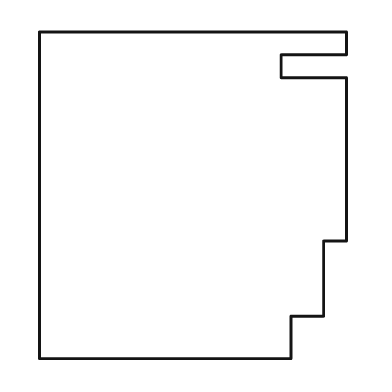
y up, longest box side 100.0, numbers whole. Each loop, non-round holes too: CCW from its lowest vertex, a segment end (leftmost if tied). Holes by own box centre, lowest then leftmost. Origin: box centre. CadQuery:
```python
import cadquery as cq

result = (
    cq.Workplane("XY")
    .moveTo(-47.0, -50.0)
    .lineTo(30.0, -50.0)
    .lineTo(30.0, -37.0)
    .lineTo(40.0, -37.0)
    .lineTo(40.0, -14.0)
    .lineTo(47.0, -14.0)
    .lineTo(47.0, 36.0)
    .lineTo(27.0, 36.0)
    .lineTo(27.0, 43.0)
    .lineTo(47.0, 43.0)
    .lineTo(47.0, 50.0)
    .lineTo(-47.0, 50.0)
    .close()
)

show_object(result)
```